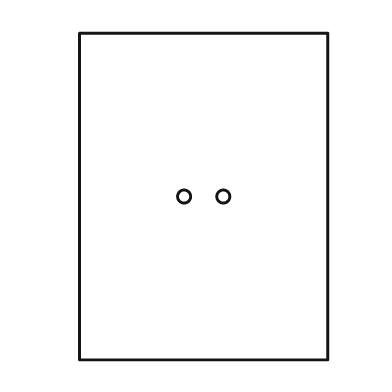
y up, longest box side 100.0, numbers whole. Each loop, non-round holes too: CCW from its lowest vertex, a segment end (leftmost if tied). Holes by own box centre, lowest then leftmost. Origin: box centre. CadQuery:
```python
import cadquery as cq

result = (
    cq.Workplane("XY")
    .moveTo(-38.0, -50.0)
    .lineTo(38.0, -50.0)
    .lineTo(38.0, 50.0)
    .lineTo(-38.0, 50.0)
    .close()
    .moveTo(-6.0, 0.0)
    .circle(2.0)
    .moveTo(6.0, 0.0)
    .circle(2.0)
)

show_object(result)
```